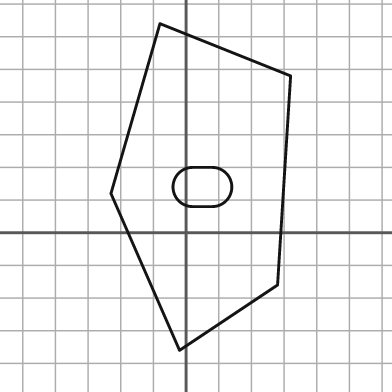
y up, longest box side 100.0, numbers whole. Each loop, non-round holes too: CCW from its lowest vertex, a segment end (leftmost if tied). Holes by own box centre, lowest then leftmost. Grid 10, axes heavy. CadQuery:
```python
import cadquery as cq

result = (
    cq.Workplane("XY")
    .moveTo(-2.0, -36.0)
    .lineTo(28.0, -16.0)
    .lineTo(32.0, 48.0)
    .lineTo(-8.0, 64.0)
    .lineTo(-23.0, 12.0)
    .close()
    .moveTo(2.0, 8.0)
    .lineTo(8.0, 8.0)
    .threePointArc((14.0, 14.0), (8.0, 20.0))
    .lineTo(2.0, 20.0)
    .threePointArc((-4.0, 14.0), (2.0, 8.0))
    .close()
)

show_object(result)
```